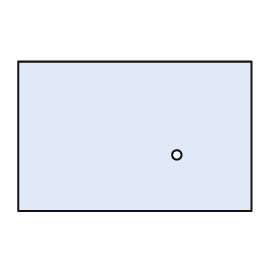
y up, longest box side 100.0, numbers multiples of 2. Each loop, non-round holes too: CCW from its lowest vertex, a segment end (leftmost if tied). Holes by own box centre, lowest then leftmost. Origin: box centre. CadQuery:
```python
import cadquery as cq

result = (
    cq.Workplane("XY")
    .moveTo(-50.0, -32.0)
    .lineTo(50.0, -32.0)
    .lineTo(50.0, 32.0)
    .lineTo(-50.0, 32.0)
    .close()
    .moveTo(18.0, -8.0)
    .circle(2.0)
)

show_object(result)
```